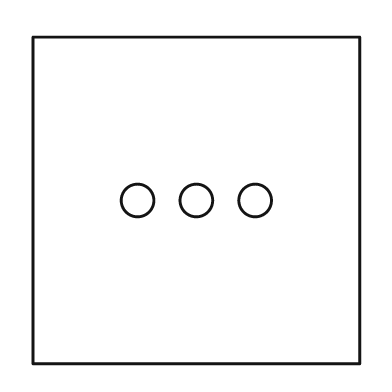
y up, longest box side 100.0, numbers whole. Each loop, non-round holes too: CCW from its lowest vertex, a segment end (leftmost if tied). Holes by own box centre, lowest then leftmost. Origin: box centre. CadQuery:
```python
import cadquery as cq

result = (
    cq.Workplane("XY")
    .moveTo(-50.0, -50.0)
    .lineTo(50.0, -50.0)
    .lineTo(50.0, 50.0)
    .lineTo(-50.0, 50.0)
    .close()
    .moveTo(-18.0, 0.0)
    .circle(5.0)
    .moveTo(0.0, 0.0)
    .circle(5.0)
    .moveTo(18.0, 0.0)
    .circle(5.0)
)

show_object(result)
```